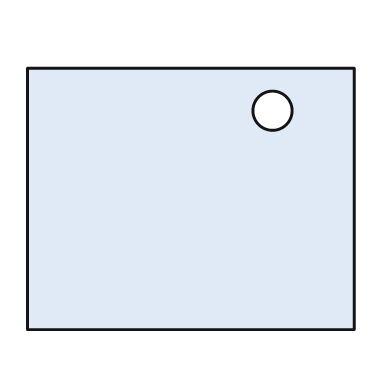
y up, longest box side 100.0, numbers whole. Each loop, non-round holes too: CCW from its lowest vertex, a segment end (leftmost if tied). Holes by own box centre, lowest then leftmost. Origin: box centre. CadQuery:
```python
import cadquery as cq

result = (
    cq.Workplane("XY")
    .moveTo(-50.0, -40.0)
    .lineTo(50.0, -40.0)
    .lineTo(50.0, 40.0)
    .lineTo(-50.0, 40.0)
    .close()
    .moveTo(25.0, 27.0)
    .circle(6.0)
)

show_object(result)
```